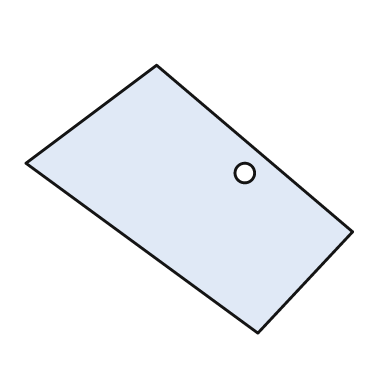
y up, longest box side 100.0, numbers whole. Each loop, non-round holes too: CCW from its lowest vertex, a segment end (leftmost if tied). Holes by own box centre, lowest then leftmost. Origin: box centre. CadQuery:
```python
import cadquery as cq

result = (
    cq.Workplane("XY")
    .moveTo(21.0, -41.0)
    .lineTo(50.0, -10.0)
    .lineTo(-10.0, 41.0)
    .lineTo(-50.0, 11.0)
    .close()
    .moveTo(17.0, 8.0)
    .circle(3.0)
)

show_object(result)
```